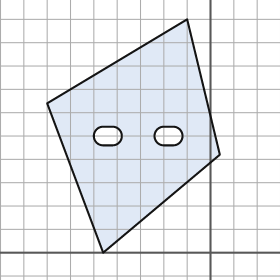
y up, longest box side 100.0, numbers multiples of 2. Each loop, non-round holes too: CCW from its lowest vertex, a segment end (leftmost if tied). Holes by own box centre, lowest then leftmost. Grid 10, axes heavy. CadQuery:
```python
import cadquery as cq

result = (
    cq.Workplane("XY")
    .moveTo(-46.0, 0.0)
    .lineTo(4.0, 42.0)
    .lineTo(-10.0, 100.0)
    .lineTo(-70.0, 64.0)
    .close()
    .moveTo(-46.0, 46.0)
    .lineTo(-42.0, 46.0)
    .threePointArc((-38.0, 50.0), (-42.0, 54.0))
    .lineTo(-46.0, 54.0)
    .threePointArc((-50.0, 50.0), (-46.0, 46.0))
    .close()
    .moveTo(-20.0, 46.0)
    .lineTo(-16.0, 46.0)
    .threePointArc((-12.0, 50.0), (-16.0, 54.0))
    .lineTo(-20.0, 54.0)
    .threePointArc((-24.0, 50.0), (-20.0, 46.0))
    .close()
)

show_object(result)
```